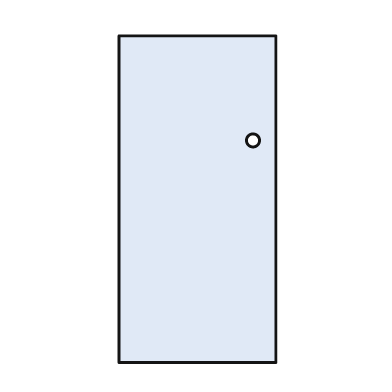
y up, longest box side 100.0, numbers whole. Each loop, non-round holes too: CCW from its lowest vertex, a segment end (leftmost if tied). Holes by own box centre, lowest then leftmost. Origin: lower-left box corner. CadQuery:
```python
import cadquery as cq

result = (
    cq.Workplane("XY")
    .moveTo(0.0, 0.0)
    .lineTo(48.0, 0.0)
    .lineTo(48.0, 100.0)
    .lineTo(0.0, 100.0)
    .close()
    .moveTo(41.0, 68.0)
    .circle(2.0)
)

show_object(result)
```